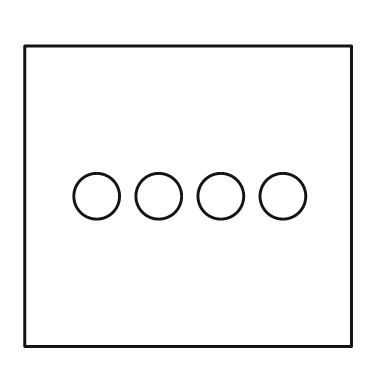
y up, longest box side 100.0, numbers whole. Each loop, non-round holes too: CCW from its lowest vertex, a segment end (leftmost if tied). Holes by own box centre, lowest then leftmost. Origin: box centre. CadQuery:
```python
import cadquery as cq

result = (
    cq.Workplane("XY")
    .moveTo(-50.0, -46.0)
    .lineTo(50.0, -46.0)
    .lineTo(50.0, 46.0)
    .lineTo(-50.0, 46.0)
    .close()
    .moveTo(-28.0, 0.0)
    .circle(7.0)
    .moveTo(-9.0, 0.0)
    .circle(7.0)
    .moveTo(10.0, 0.0)
    .circle(7.0)
    .moveTo(29.0, 0.0)
    .circle(7.0)
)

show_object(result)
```